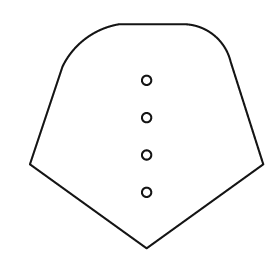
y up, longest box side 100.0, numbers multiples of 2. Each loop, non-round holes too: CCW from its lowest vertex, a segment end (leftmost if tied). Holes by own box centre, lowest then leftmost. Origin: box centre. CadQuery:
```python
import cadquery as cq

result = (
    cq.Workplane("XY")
    .moveTo(0.0, -48.0)
    .lineTo(50.0, -12.0)
    .lineTo(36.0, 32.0)
    .threePointArc((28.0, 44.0), (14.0, 48.0))
    .lineTo(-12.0, 48.0)
    .threePointArc((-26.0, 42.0), (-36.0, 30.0))
    .lineTo(-50.0, -12.0)
    .close()
    .moveTo(0.0, -24.0)
    .circle(2.0)
    .moveTo(0.0, -8.0)
    .circle(2.0)
    .moveTo(0.0, 8.0)
    .circle(2.0)
    .moveTo(0.0, 24.0)
    .circle(2.0)
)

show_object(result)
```